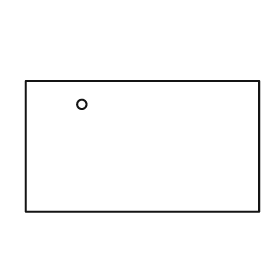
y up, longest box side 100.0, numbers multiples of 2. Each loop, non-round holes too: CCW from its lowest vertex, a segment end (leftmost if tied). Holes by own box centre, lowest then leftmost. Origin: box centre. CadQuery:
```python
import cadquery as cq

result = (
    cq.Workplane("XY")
    .moveTo(-50.0, -28.0)
    .lineTo(50.0, -28.0)
    .lineTo(50.0, 28.0)
    .lineTo(-50.0, 28.0)
    .close()
    .moveTo(-26.0, 18.0)
    .circle(2.0)
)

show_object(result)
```